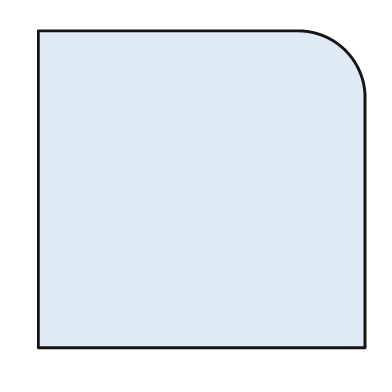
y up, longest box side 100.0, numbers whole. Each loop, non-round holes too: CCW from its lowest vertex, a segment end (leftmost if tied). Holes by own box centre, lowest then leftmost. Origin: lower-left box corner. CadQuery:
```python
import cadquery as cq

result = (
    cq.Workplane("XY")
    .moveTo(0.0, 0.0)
    .lineTo(100.0, 0.0)
    .lineTo(100.0, 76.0)
    .threePointArc((94.0, 91.0), (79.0, 97.0))
    .lineTo(0.0, 97.0)
    .close()
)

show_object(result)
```